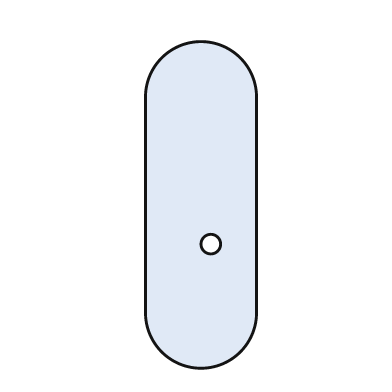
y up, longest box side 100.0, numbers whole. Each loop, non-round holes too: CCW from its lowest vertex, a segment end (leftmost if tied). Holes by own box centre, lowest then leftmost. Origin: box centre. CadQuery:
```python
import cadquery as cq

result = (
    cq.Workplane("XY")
    .moveTo(-17.0, -33.0)
    .threePointArc((0.0, -50.0), (17.0, -33.0))
    .lineTo(17.0, 33.0)
    .threePointArc((0.0, 50.0), (-17.0, 33.0))
    .close()
    .moveTo(3.0, -12.0)
    .circle(3.0)
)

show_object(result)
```